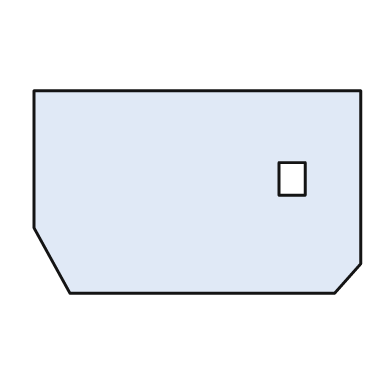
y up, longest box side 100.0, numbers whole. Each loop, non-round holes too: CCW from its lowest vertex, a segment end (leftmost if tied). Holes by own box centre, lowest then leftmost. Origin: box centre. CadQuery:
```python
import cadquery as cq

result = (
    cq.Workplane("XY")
    .moveTo(-39.0, -31.0)
    .lineTo(42.0, -31.0)
    .lineTo(50.0, -22.0)
    .lineTo(50.0, 31.0)
    .lineTo(-50.0, 31.0)
    .lineTo(-50.0, -11.0)
    .close()
    .moveTo(25.0, -1.0)
    .lineTo(33.0, -1.0)
    .lineTo(33.0, 9.0)
    .lineTo(25.0, 9.0)
    .close()
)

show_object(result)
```